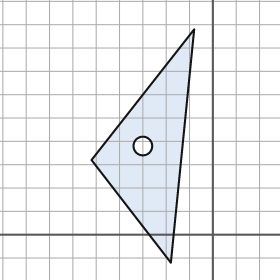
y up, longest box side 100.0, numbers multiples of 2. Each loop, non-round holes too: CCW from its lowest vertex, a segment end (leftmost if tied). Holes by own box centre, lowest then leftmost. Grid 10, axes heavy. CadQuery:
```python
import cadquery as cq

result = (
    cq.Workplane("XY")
    .moveTo(-18.0, -12.0)
    .lineTo(-8.0, 88.0)
    .lineTo(-52.0, 32.0)
    .close()
    .moveTo(-30.0, 38.0)
    .circle(4.0)
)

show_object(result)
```